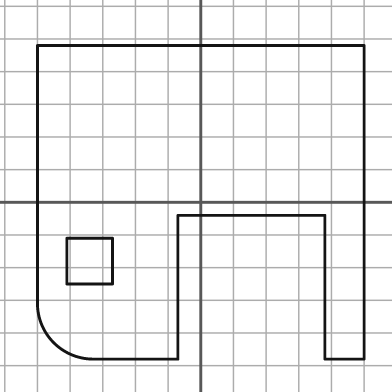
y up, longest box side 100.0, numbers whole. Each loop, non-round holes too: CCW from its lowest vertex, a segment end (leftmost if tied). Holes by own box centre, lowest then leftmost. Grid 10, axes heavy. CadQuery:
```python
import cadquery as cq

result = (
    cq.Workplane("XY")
    .moveTo(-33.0, -48.0)
    .lineTo(-7.0, -48.0)
    .lineTo(-7.0, -4.0)
    .lineTo(38.0, -4.0)
    .lineTo(38.0, -48.0)
    .lineTo(50.0, -48.0)
    .lineTo(50.0, 48.0)
    .lineTo(-50.0, 48.0)
    .lineTo(-50.0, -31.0)
    .threePointArc((-45.0, -43.0), (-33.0, -48.0))
    .close()
    .moveTo(-41.0, -25.0)
    .lineTo(-27.0, -25.0)
    .lineTo(-27.0, -11.0)
    .lineTo(-41.0, -11.0)
    .close()
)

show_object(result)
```